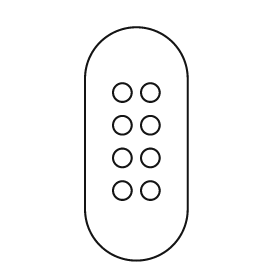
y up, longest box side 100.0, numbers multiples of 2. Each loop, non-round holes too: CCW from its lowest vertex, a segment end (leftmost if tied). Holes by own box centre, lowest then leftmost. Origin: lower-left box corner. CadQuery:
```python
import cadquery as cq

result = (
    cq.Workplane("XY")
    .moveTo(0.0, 22.0)
    .threePointArc((22.0, 0.0), (44.0, 22.0))
    .lineTo(44.0, 78.0)
    .threePointArc((22.0, 100.0), (0.0, 78.0))
    .close()
    .moveTo(16.0, 30.0)
    .circle(4.0)
    .moveTo(28.0, 30.0)
    .circle(4.0)
    .moveTo(16.0, 44.0)
    .circle(4.0)
    .moveTo(28.0, 44.0)
    .circle(4.0)
    .moveTo(16.0, 58.0)
    .circle(4.0)
    .moveTo(28.0, 58.0)
    .circle(4.0)
    .moveTo(16.0, 72.0)
    .circle(4.0)
    .moveTo(28.0, 72.0)
    .circle(4.0)
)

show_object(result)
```